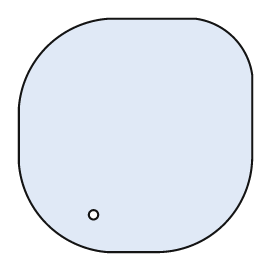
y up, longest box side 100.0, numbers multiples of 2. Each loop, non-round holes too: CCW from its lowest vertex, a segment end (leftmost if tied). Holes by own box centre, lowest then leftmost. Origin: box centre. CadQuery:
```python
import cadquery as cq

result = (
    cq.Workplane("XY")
    .moveTo(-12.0, -50.0)
    .lineTo(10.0, -50.0)
    .threePointArc((38.0, -38.0), (50.0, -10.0))
    .lineTo(50.0, 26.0)
    .threePointArc((42.0, 42.0), (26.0, 50.0))
    .lineTo(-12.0, 50.0)
    .threePointArc((-38.0, 38.0), (-50.0, 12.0))
    .lineTo(-50.0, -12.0)
    .threePointArc((-38.0, -38.0), (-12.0, -50.0))
    .close()
    .moveTo(-18.0, -34.0)
    .circle(2.0)
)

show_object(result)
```